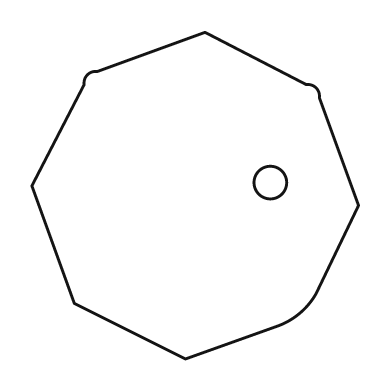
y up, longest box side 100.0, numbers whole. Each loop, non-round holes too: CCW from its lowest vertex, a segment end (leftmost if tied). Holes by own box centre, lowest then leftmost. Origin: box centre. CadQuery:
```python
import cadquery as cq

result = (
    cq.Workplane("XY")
    .moveTo(-3.0, -50.0)
    .lineTo(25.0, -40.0)
    .threePointArc((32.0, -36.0), (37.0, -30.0))
    .lineTo(50.0, -3.0)
    .lineTo(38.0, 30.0)
    .threePointArc((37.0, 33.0), (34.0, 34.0))
    .lineTo(3.0, 50.0)
    .lineTo(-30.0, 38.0)
    .threePointArc((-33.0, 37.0), (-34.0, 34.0))
    .lineTo(-50.0, 3.0)
    .lineTo(-37.0, -33.0)
    .close()
    .moveTo(23.0, 4.0)
    .circle(5.0)
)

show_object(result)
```